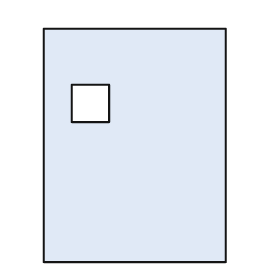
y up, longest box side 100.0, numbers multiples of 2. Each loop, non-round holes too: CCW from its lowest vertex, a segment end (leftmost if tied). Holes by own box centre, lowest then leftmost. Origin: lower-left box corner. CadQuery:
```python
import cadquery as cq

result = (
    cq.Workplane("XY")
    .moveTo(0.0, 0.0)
    .lineTo(78.0, 0.0)
    .lineTo(78.0, 100.0)
    .lineTo(0.0, 100.0)
    .close()
    .moveTo(12.0, 60.0)
    .lineTo(28.0, 60.0)
    .lineTo(28.0, 76.0)
    .lineTo(12.0, 76.0)
    .close()
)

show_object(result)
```